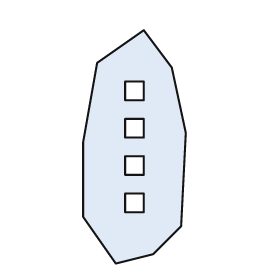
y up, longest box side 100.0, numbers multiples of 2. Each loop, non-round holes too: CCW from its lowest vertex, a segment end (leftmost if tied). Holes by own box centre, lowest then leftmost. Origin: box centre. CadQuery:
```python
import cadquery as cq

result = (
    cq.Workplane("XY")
    .moveTo(-8.0, -50.0)
    .lineTo(8.0, -46.0)
    .lineTo(20.0, -34.0)
    .lineTo(22.0, 6.0)
    .lineTo(16.0, 34.0)
    .lineTo(4.0, 50.0)
    .lineTo(-16.0, 36.0)
    .lineTo(-22.0, 2.0)
    .lineTo(-22.0, -30.0)
    .close()
    .moveTo(-4.0, -28.0)
    .lineTo(4.0, -28.0)
    .lineTo(4.0, -20.0)
    .lineTo(-4.0, -20.0)
    .close()
    .moveTo(-4.0, -12.0)
    .lineTo(4.0, -12.0)
    .lineTo(4.0, -4.0)
    .lineTo(-4.0, -4.0)
    .close()
    .moveTo(-4.0, 4.0)
    .lineTo(4.0, 4.0)
    .lineTo(4.0, 12.0)
    .lineTo(-4.0, 12.0)
    .close()
    .moveTo(-4.0, 20.0)
    .lineTo(4.0, 20.0)
    .lineTo(4.0, 28.0)
    .lineTo(-4.0, 28.0)
    .close()
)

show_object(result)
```